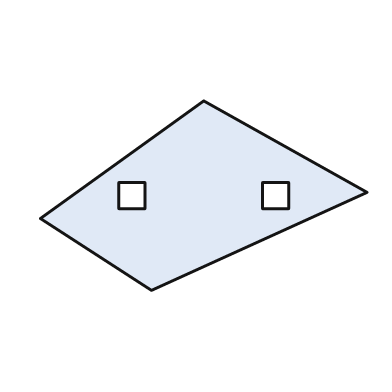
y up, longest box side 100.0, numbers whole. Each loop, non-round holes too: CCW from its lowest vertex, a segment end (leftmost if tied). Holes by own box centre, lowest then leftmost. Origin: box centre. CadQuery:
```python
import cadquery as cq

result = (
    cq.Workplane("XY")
    .moveTo(-16.0, -29.0)
    .lineTo(50.0, 1.0)
    .lineTo(0.0, 29.0)
    .lineTo(-50.0, -7.0)
    .close()
    .moveTo(-26.0, -4.0)
    .lineTo(-18.0, -4.0)
    .lineTo(-18.0, 4.0)
    .lineTo(-26.0, 4.0)
    .close()
    .moveTo(18.0, -4.0)
    .lineTo(26.0, -4.0)
    .lineTo(26.0, 4.0)
    .lineTo(18.0, 4.0)
    .close()
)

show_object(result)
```